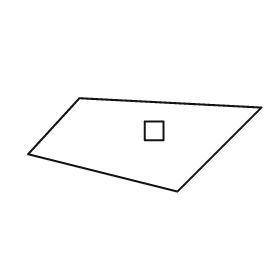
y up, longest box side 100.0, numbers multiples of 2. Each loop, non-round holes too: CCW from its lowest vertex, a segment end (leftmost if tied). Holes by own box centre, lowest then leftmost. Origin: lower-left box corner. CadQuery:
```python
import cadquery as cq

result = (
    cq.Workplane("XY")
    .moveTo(64.0, 0.0)
    .lineTo(100.0, 36.0)
    .lineTo(22.0, 40.0)
    .lineTo(0.0, 16.0)
    .close()
    .moveTo(50.0, 22.0)
    .lineTo(58.0, 22.0)
    .lineTo(58.0, 30.0)
    .lineTo(50.0, 30.0)
    .close()
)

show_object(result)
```